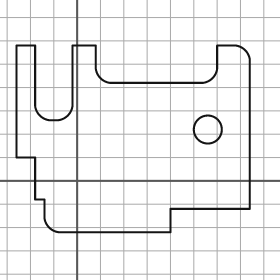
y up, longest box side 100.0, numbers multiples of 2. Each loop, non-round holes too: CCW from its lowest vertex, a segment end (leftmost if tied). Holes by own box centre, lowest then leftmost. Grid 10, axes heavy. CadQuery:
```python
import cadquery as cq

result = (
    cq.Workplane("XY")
    .moveTo(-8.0, -22.0)
    .lineTo(40.0, -22.0)
    .lineTo(40.0, -12.0)
    .lineTo(74.0, -12.0)
    .lineTo(74.0, 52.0)
    .threePointArc((72.0, 56.0), (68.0, 58.0))
    .lineTo(60.0, 58.0)
    .lineTo(60.0, 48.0)
    .threePointArc((58.0, 44.0), (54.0, 42.0))
    .lineTo(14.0, 42.0)
    .threePointArc((10.0, 44.0), (8.0, 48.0))
    .lineTo(8.0, 58.0)
    .lineTo(-2.0, 58.0)
    .lineTo(-2.0, 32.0)
    .threePointArc((-4.0, 28.0), (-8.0, 26.0))
    .lineTo(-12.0, 26.0)
    .threePointArc((-16.0, 28.0), (-18.0, 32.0))
    .lineTo(-18.0, 58.0)
    .lineTo(-26.0, 58.0)
    .lineTo(-26.0, 10.0)
    .lineTo(-18.0, 10.0)
    .lineTo(-18.0, -8.0)
    .lineTo(-14.0, -8.0)
    .lineTo(-14.0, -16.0)
    .threePointArc((-12.0, -20.0), (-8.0, -22.0))
    .close()
    .moveTo(56.0, 22.0)
    .circle(6.0)
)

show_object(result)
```